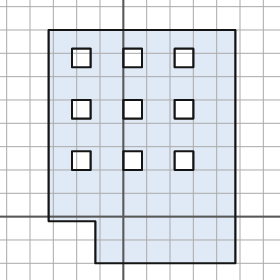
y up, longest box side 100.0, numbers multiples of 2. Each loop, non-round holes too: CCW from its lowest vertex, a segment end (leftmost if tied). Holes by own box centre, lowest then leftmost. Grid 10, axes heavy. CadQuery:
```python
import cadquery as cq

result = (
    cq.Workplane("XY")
    .moveTo(-12.0, -20.0)
    .lineTo(48.0, -20.0)
    .lineTo(48.0, 80.0)
    .lineTo(-32.0, 80.0)
    .lineTo(-32.0, -2.0)
    .lineTo(-12.0, -2.0)
    .close()
    .moveTo(-22.0, 20.0)
    .lineTo(-14.0, 20.0)
    .lineTo(-14.0, 28.0)
    .lineTo(-22.0, 28.0)
    .close()
    .moveTo(0.0, 20.0)
    .lineTo(8.0, 20.0)
    .lineTo(8.0, 28.0)
    .lineTo(0.0, 28.0)
    .close()
    .moveTo(22.0, 20.0)
    .lineTo(30.0, 20.0)
    .lineTo(30.0, 28.0)
    .lineTo(22.0, 28.0)
    .close()
    .moveTo(-22.0, 42.0)
    .lineTo(-14.0, 42.0)
    .lineTo(-14.0, 50.0)
    .lineTo(-22.0, 50.0)
    .close()
    .moveTo(0.0, 42.0)
    .lineTo(8.0, 42.0)
    .lineTo(8.0, 50.0)
    .lineTo(0.0, 50.0)
    .close()
    .moveTo(22.0, 42.0)
    .lineTo(30.0, 42.0)
    .lineTo(30.0, 50.0)
    .lineTo(22.0, 50.0)
    .close()
    .moveTo(-22.0, 64.0)
    .lineTo(-14.0, 64.0)
    .lineTo(-14.0, 72.0)
    .lineTo(-22.0, 72.0)
    .close()
    .moveTo(0.0, 64.0)
    .lineTo(8.0, 64.0)
    .lineTo(8.0, 72.0)
    .lineTo(0.0, 72.0)
    .close()
    .moveTo(22.0, 64.0)
    .lineTo(30.0, 64.0)
    .lineTo(30.0, 72.0)
    .lineTo(22.0, 72.0)
    .close()
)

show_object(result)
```